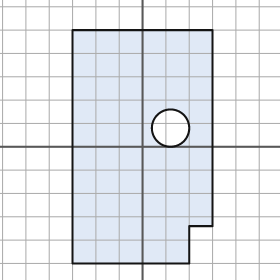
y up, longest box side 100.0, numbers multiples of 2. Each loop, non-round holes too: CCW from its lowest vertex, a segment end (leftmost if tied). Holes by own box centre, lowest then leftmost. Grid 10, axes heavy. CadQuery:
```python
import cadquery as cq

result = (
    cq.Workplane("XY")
    .moveTo(-30.0, -50.0)
    .lineTo(20.0, -50.0)
    .lineTo(20.0, -34.0)
    .lineTo(30.0, -34.0)
    .lineTo(30.0, 50.0)
    .lineTo(-30.0, 50.0)
    .close()
    .moveTo(12.0, 8.0)
    .circle(8.0)
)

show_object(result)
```